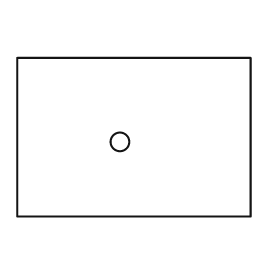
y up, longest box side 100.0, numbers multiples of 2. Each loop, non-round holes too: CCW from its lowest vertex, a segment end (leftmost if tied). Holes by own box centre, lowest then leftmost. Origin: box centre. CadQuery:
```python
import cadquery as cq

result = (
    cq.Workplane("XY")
    .moveTo(-50.0, -34.0)
    .lineTo(50.0, -34.0)
    .lineTo(50.0, 34.0)
    .lineTo(-50.0, 34.0)
    .close()
    .moveTo(-6.0, -2.0)
    .circle(4.0)
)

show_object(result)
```